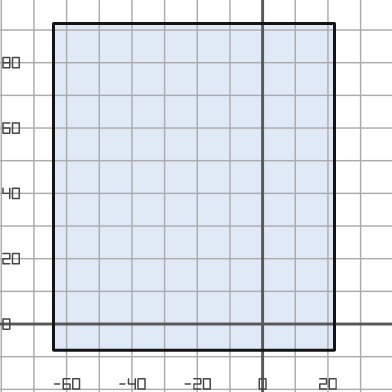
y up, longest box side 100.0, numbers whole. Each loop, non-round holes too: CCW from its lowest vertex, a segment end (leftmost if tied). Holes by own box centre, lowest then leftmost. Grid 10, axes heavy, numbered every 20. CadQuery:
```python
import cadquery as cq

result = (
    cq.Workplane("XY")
    .moveTo(-64.0, -8.0)
    .lineTo(22.0, -8.0)
    .lineTo(22.0, 92.0)
    .lineTo(-64.0, 92.0)
    .close()
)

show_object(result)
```